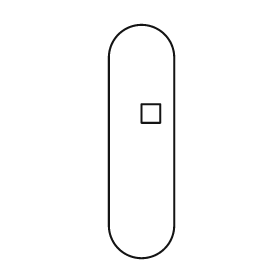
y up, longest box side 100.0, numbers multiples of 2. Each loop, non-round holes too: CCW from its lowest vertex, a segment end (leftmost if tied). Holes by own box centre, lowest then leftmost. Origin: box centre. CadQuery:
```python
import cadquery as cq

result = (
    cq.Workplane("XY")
    .moveTo(-14.0, -36.0)
    .threePointArc((0.0, -50.0), (14.0, -36.0))
    .lineTo(14.0, 36.0)
    .threePointArc((0.0, 50.0), (-14.0, 36.0))
    .close()
    .moveTo(0.0, 8.0)
    .lineTo(8.0, 8.0)
    .lineTo(8.0, 16.0)
    .lineTo(0.0, 16.0)
    .close()
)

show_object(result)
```